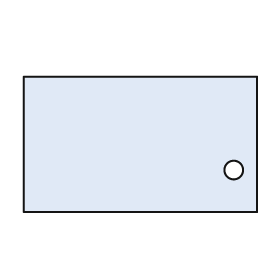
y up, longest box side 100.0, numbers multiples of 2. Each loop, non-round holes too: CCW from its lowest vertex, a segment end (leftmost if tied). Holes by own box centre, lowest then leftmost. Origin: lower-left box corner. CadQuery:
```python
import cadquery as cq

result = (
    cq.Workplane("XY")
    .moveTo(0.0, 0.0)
    .lineTo(100.0, 0.0)
    .lineTo(100.0, 58.0)
    .lineTo(0.0, 58.0)
    .close()
    .moveTo(90.0, 18.0)
    .circle(4.0)
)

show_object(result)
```